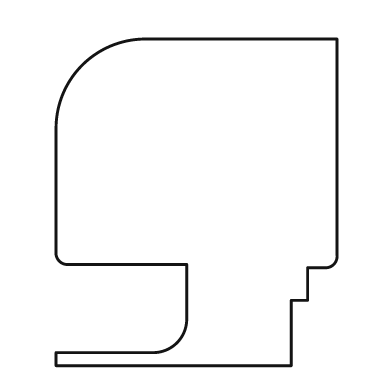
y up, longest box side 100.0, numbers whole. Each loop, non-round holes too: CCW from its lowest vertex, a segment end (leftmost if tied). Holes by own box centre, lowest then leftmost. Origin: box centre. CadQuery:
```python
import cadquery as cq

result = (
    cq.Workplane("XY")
    .moveTo(-43.0, -50.0)
    .lineTo(29.0, -50.0)
    .lineTo(29.0, -30.0)
    .lineTo(34.0, -30.0)
    .lineTo(34.0, -20.0)
    .lineTo(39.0, -20.0)
    .threePointArc((42.0, -19.0), (43.0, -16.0))
    .lineTo(43.0, 50.0)
    .lineTo(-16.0, 50.0)
    .threePointArc((-35.0, 42.0), (-43.0, 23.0))
    .lineTo(-43.0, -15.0)
    .threePointArc((-42.0, -18.0), (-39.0, -19.0))
    .lineTo(-3.0, -19.0)
    .lineTo(-3.0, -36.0)
    .threePointArc((-6.0, -43.0), (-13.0, -46.0))
    .lineTo(-43.0, -46.0)
    .close()
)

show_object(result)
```